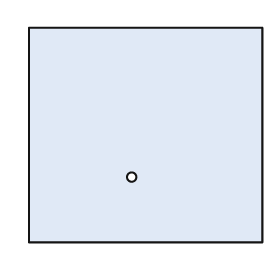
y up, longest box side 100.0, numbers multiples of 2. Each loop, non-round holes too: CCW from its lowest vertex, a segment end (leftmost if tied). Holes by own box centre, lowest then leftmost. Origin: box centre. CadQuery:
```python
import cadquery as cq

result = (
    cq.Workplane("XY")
    .moveTo(-50.0, -46.0)
    .lineTo(50.0, -46.0)
    .lineTo(50.0, 46.0)
    .lineTo(-50.0, 46.0)
    .close()
    .moveTo(-6.0, -18.0)
    .circle(2.0)
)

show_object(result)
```